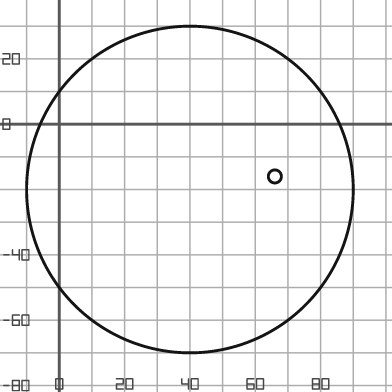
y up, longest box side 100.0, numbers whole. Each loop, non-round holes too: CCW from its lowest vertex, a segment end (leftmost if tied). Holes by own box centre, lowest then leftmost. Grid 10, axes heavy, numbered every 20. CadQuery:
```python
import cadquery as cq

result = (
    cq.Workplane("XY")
    .moveTo(40.0, -20.0)
    .circle(50.0)
    .moveTo(66.0, -16.0)
    .circle(2.0)
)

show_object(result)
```